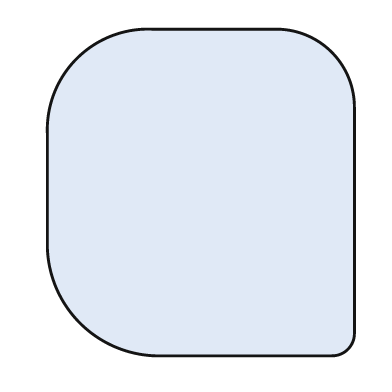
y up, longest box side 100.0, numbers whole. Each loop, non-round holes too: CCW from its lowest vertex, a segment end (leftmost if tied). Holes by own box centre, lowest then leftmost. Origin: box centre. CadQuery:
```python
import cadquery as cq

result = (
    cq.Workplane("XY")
    .moveTo(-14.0, -50.0)
    .lineTo(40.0, -50.0)
    .threePointArc((45.0, -48.0), (47.0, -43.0))
    .lineTo(47.0, 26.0)
    .threePointArc((40.0, 43.0), (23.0, 50.0))
    .lineTo(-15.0, 50.0)
    .threePointArc((-38.0, 41.0), (-47.0, 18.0))
    .lineTo(-47.0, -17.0)
    .threePointArc((-37.0, -40.0), (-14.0, -50.0))
    .close()
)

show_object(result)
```